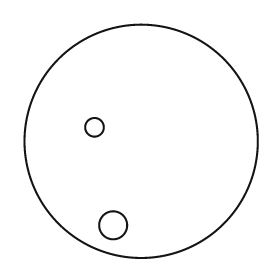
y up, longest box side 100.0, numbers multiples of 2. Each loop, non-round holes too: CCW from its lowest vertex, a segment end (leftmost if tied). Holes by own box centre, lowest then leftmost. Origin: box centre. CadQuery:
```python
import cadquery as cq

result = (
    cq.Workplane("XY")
    .moveTo(0.0, 0.0)
    .circle(50.0)
    .moveTo(-12.0, -36.0)
    .circle(6.0)
    .moveTo(-20.0, 6.0)
    .circle(4.0)
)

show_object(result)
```